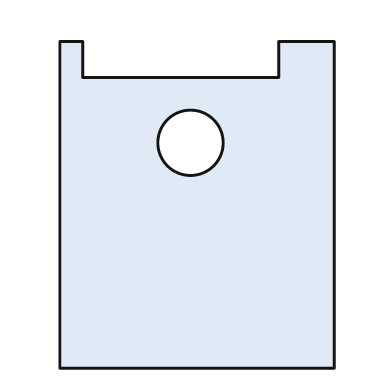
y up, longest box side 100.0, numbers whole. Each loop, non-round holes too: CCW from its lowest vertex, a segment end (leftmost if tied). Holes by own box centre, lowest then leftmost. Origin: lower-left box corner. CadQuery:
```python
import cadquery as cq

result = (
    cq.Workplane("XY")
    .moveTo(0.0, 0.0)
    .lineTo(84.0, 0.0)
    .lineTo(84.0, 100.0)
    .lineTo(67.0, 100.0)
    .lineTo(67.0, 89.0)
    .lineTo(7.0, 89.0)
    .lineTo(7.0, 100.0)
    .lineTo(0.0, 100.0)
    .close()
    .moveTo(40.0, 69.0)
    .circle(10.0)
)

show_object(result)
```